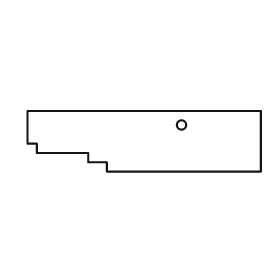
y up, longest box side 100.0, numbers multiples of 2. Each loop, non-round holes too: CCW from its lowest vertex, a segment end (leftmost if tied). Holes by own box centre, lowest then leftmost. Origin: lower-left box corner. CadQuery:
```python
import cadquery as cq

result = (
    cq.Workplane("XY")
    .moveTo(34.0, 0.0)
    .lineTo(100.0, 0.0)
    .lineTo(100.0, 26.0)
    .lineTo(0.0, 26.0)
    .lineTo(0.0, 12.0)
    .lineTo(4.0, 12.0)
    .lineTo(4.0, 8.0)
    .lineTo(26.0, 8.0)
    .lineTo(26.0, 4.0)
    .lineTo(34.0, 4.0)
    .close()
    .moveTo(66.0, 20.0)
    .circle(2.0)
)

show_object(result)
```